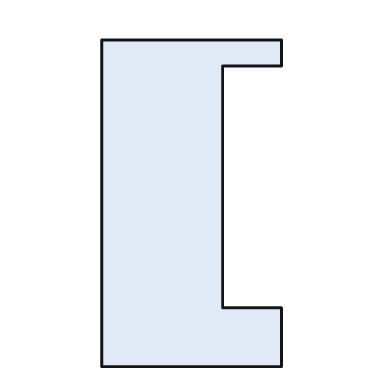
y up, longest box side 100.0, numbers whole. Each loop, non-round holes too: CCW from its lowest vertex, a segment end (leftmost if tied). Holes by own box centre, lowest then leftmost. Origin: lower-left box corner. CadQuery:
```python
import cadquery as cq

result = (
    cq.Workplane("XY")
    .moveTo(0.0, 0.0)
    .lineTo(55.0, 0.0)
    .lineTo(55.0, 18.0)
    .lineTo(37.0, 18.0)
    .lineTo(37.0, 92.0)
    .lineTo(55.0, 92.0)
    .lineTo(55.0, 100.0)
    .lineTo(0.0, 100.0)
    .close()
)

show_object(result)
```